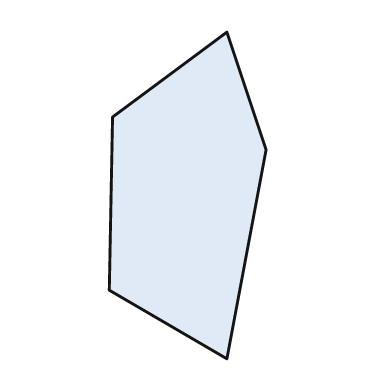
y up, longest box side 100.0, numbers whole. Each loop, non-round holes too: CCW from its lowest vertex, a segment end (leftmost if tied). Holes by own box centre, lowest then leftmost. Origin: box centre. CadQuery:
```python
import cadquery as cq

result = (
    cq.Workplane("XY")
    .moveTo(12.0, -50.0)
    .lineTo(24.0, 14.0)
    .lineTo(12.0, 50.0)
    .lineTo(-23.0, 24.0)
    .lineTo(-24.0, -29.0)
    .close()
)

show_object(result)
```